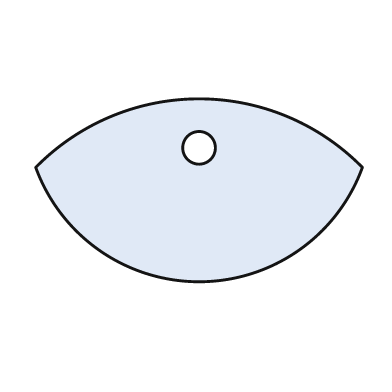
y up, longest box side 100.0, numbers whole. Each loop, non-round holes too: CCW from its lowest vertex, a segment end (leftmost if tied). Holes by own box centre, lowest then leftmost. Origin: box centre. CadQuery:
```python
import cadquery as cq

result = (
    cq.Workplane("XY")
    .moveTo(-50.0, 7.0)
    .threePointArc((0.0, -28.0), (50.0, 7.0))
    .threePointArc((0.0, 28.0), (-50.0, 7.0))
    .close()
    .moveTo(0.0, 13.0)
    .circle(5.0)
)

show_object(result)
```